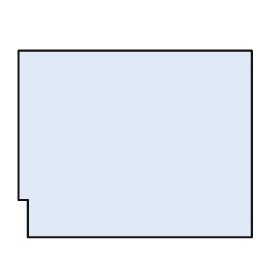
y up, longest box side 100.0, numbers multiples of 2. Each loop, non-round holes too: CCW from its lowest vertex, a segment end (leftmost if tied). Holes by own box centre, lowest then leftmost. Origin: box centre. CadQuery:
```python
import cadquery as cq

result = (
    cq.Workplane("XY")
    .moveTo(-46.0, -40.0)
    .lineTo(50.0, -40.0)
    .lineTo(50.0, 40.0)
    .lineTo(-50.0, 40.0)
    .lineTo(-50.0, -24.0)
    .lineTo(-46.0, -24.0)
    .close()
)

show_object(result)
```